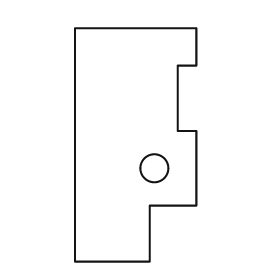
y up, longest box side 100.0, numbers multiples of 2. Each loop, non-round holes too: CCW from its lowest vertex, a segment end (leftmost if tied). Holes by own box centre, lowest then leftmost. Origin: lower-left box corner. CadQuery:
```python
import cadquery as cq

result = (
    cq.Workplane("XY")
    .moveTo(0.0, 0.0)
    .lineTo(32.0, 0.0)
    .lineTo(32.0, 24.0)
    .lineTo(52.0, 24.0)
    .lineTo(52.0, 56.0)
    .lineTo(44.0, 56.0)
    .lineTo(44.0, 84.0)
    .lineTo(52.0, 84.0)
    .lineTo(52.0, 100.0)
    .lineTo(0.0, 100.0)
    .close()
    .moveTo(34.0, 40.0)
    .circle(6.0)
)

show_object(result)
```